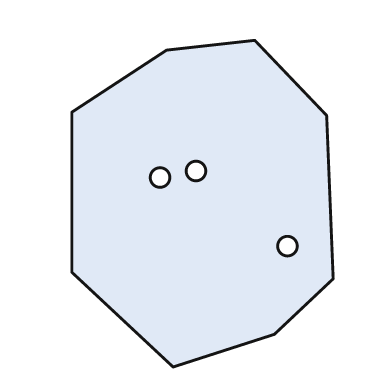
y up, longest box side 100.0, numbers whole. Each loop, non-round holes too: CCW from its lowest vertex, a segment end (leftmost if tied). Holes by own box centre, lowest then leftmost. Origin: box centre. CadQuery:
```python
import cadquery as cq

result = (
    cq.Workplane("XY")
    .moveTo(-9.0, -50.0)
    .lineTo(22.0, -40.0)
    .lineTo(40.0, -23.0)
    .lineTo(38.0, 27.0)
    .lineTo(16.0, 50.0)
    .lineTo(-11.0, 47.0)
    .lineTo(-40.0, 28.0)
    .lineTo(-40.0, -21.0)
    .close()
    .moveTo(26.0, -13.0)
    .circle(3.0)
    .moveTo(-13.0, 8.0)
    .circle(3.0)
    .moveTo(-2.0, 10.0)
    .circle(3.0)
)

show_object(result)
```